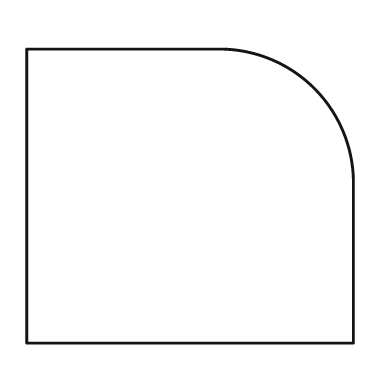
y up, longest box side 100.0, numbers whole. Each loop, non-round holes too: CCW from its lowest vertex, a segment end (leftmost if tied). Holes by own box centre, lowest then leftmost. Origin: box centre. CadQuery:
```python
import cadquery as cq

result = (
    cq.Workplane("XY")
    .moveTo(-50.0, -45.0)
    .lineTo(50.0, -45.0)
    .lineTo(50.0, 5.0)
    .threePointArc((38.0, 33.0), (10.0, 45.0))
    .lineTo(-50.0, 45.0)
    .close()
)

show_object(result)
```